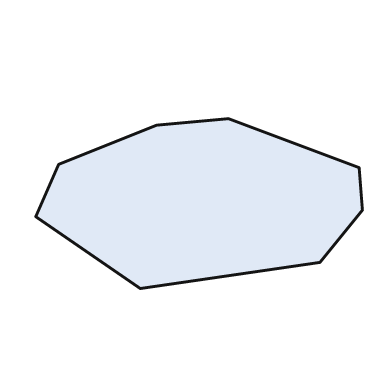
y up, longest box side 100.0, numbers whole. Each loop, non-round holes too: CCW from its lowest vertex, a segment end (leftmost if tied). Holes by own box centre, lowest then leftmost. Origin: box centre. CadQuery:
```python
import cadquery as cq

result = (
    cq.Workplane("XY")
    .moveTo(-18.0, -26.0)
    .lineTo(37.0, -18.0)
    .lineTo(50.0, -2.0)
    .lineTo(49.0, 11.0)
    .lineTo(9.0, 26.0)
    .lineTo(-13.0, 24.0)
    .lineTo(-43.0, 12.0)
    .lineTo(-50.0, -4.0)
    .close()
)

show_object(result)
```